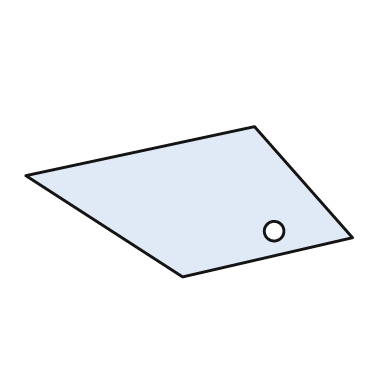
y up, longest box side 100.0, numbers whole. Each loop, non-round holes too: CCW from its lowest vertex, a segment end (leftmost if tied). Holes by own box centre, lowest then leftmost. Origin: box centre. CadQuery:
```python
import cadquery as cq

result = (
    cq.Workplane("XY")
    .moveTo(-2.0, -23.0)
    .lineTo(50.0, -11.0)
    .lineTo(20.0, 23.0)
    .lineTo(-50.0, 8.0)
    .close()
    .moveTo(26.0, -9.0)
    .circle(3.0)
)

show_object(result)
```